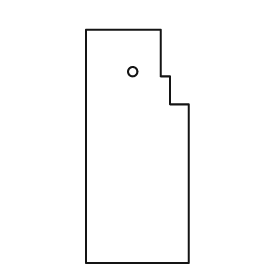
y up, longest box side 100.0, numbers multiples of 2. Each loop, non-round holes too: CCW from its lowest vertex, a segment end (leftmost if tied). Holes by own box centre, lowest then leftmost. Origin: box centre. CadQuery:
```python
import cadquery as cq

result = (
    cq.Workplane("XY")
    .moveTo(-22.0, -50.0)
    .lineTo(22.0, -50.0)
    .lineTo(22.0, 18.0)
    .lineTo(14.0, 18.0)
    .lineTo(14.0, 30.0)
    .lineTo(10.0, 30.0)
    .lineTo(10.0, 50.0)
    .lineTo(-22.0, 50.0)
    .close()
    .moveTo(-2.0, 32.0)
    .circle(2.0)
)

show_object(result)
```